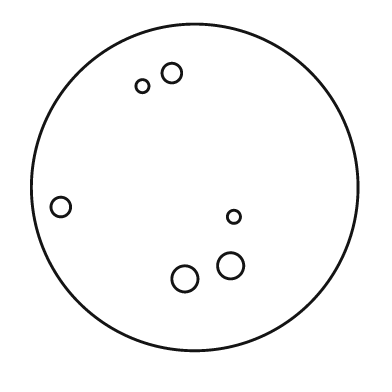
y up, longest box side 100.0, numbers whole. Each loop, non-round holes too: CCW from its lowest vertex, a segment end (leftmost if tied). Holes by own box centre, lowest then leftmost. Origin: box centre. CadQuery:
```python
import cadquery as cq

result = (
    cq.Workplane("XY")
    .moveTo(0.0, 0.0)
    .circle(50.0)
    .moveTo(-3.0, -28.0)
    .circle(4.0)
    .moveTo(11.0, -24.0)
    .circle(4.0)
    .moveTo(12.0, -9.0)
    .circle(2.0)
    .moveTo(-41.0, -6.0)
    .circle(3.0)
    .moveTo(-16.0, 31.0)
    .circle(2.0)
    .moveTo(-7.0, 35.0)
    .circle(3.0)
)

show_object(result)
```